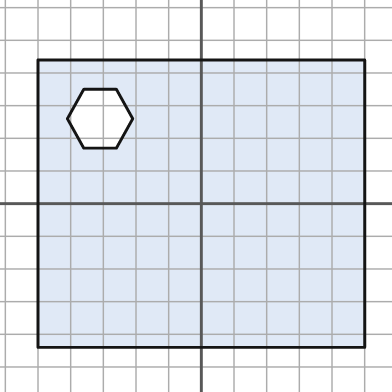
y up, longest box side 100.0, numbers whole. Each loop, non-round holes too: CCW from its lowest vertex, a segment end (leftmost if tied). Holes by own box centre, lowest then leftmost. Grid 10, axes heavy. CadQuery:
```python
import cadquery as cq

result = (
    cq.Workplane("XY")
    .moveTo(-50.0, -44.0)
    .lineTo(50.0, -44.0)
    .lineTo(50.0, 44.0)
    .lineTo(-50.0, 44.0)
    .close()
    .moveTo(-36.0, 17.0)
    .lineTo(-26.0, 17.0)
    .lineTo(-21.0, 26.0)
    .lineTo(-26.0, 35.0)
    .lineTo(-36.0, 35.0)
    .lineTo(-41.0, 26.0)
    .close()
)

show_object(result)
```